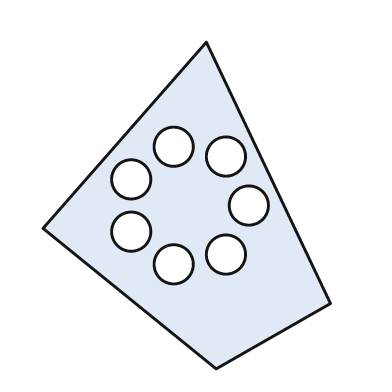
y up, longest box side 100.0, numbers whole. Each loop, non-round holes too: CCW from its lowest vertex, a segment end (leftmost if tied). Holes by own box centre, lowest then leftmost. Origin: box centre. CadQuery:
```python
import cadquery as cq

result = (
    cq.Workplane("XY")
    .moveTo(9.0, -50.0)
    .lineTo(44.0, -30.0)
    .lineTo(6.0, 50.0)
    .lineTo(-44.0, -7.0)
    .close()
    .moveTo(-4.0, -18.0)
    .circle(6.0)
    .moveTo(12.0, -15.0)
    .circle(6.0)
    .moveTo(-17.0, -8.0)
    .circle(6.0)
    .moveTo(19.0, 0.0)
    .circle(6.0)
    .moveTo(-17.0, 8.0)
    .circle(6.0)
    .moveTo(12.0, 15.0)
    .circle(6.0)
    .moveTo(-4.0, 18.0)
    .circle(6.0)
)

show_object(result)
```